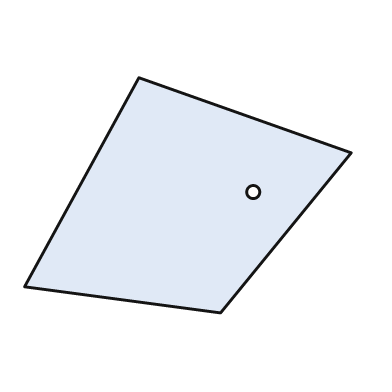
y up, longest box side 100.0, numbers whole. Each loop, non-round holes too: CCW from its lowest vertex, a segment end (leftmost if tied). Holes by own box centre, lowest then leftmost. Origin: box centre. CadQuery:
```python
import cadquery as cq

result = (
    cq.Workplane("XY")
    .moveTo(10.0, -36.0)
    .lineTo(50.0, 13.0)
    .lineTo(-15.0, 36.0)
    .lineTo(-50.0, -28.0)
    .close()
    .moveTo(20.0, 1.0)
    .circle(2.0)
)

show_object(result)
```